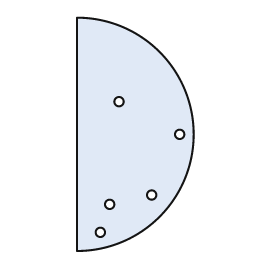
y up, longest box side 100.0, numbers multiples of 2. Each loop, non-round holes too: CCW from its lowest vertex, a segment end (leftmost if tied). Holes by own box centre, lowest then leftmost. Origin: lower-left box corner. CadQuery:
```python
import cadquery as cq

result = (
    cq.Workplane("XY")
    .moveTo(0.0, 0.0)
    .threePointArc((50.0, 50.0), (0.0, 100.0))
    .close()
    .moveTo(10.0, 8.0)
    .circle(2.0)
    .moveTo(14.0, 20.0)
    .circle(2.0)
    .moveTo(32.0, 24.0)
    .circle(2.0)
    .moveTo(44.0, 50.0)
    .circle(2.0)
    .moveTo(18.0, 64.0)
    .circle(2.0)
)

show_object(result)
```